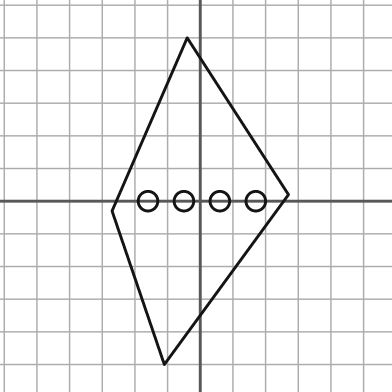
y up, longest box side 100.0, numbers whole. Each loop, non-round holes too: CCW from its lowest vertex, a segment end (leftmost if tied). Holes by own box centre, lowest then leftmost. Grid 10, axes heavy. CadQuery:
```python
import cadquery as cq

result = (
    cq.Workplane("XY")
    .moveTo(-11.0, -50.0)
    .lineTo(27.0, 2.0)
    .lineTo(-4.0, 50.0)
    .lineTo(-27.0, -3.0)
    .close()
    .moveTo(-16.0, 0.0)
    .circle(3.0)
    .moveTo(-5.0, 0.0)
    .circle(3.0)
    .moveTo(6.0, 0.0)
    .circle(3.0)
    .moveTo(17.0, 0.0)
    .circle(3.0)
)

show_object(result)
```